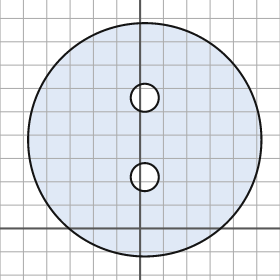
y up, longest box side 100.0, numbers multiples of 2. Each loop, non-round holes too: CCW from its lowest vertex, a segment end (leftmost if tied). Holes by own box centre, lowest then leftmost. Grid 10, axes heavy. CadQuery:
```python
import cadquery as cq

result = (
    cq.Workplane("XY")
    .moveTo(2.0, 38.0)
    .circle(50.0)
    .moveTo(2.0, 22.0)
    .circle(6.0)
    .moveTo(2.0, 56.0)
    .circle(6.0)
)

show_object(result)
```